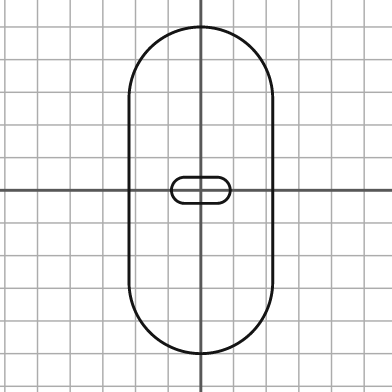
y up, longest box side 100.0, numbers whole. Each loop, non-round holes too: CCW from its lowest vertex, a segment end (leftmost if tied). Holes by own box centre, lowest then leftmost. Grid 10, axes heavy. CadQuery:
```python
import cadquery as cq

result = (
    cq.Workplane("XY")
    .moveTo(-22.0, -28.0)
    .threePointArc((0.0, -50.0), (22.0, -28.0))
    .lineTo(22.0, 28.0)
    .threePointArc((0.0, 50.0), (-22.0, 28.0))
    .close()
    .moveTo(-5.0, -4.0)
    .lineTo(5.0, -4.0)
    .threePointArc((9.0, 0.0), (5.0, 4.0))
    .lineTo(-5.0, 4.0)
    .threePointArc((-9.0, 0.0), (-5.0, -4.0))
    .close()
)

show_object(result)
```